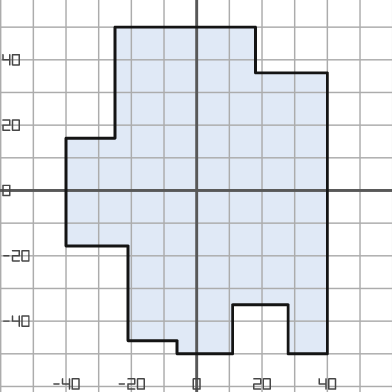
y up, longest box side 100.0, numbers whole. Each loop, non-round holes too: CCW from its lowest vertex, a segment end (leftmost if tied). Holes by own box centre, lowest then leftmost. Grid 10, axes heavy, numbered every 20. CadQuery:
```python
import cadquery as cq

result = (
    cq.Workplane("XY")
    .moveTo(-6.0, -50.0)
    .lineTo(11.0, -50.0)
    .lineTo(11.0, -35.0)
    .lineTo(28.0, -35.0)
    .lineTo(28.0, -50.0)
    .lineTo(40.0, -50.0)
    .lineTo(40.0, 36.0)
    .lineTo(18.0, 36.0)
    .lineTo(18.0, 50.0)
    .lineTo(-25.0, 50.0)
    .lineTo(-25.0, 16.0)
    .lineTo(-40.0, 16.0)
    .lineTo(-40.0, -17.0)
    .lineTo(-21.0, -17.0)
    .lineTo(-21.0, -46.0)
    .lineTo(-6.0, -46.0)
    .close()
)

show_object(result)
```